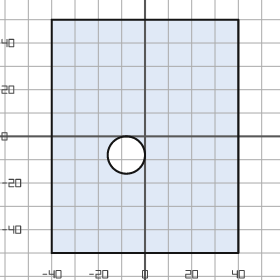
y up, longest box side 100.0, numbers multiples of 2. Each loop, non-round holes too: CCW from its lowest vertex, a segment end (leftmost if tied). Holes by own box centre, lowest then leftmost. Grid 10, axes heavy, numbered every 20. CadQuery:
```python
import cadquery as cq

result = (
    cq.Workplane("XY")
    .moveTo(-40.0, -50.0)
    .lineTo(40.0, -50.0)
    .lineTo(40.0, 50.0)
    .lineTo(-40.0, 50.0)
    .close()
    .moveTo(-8.0, -8.0)
    .circle(8.0)
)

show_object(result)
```